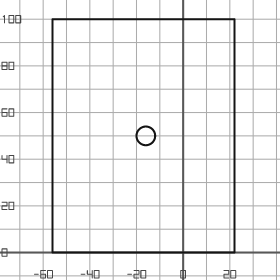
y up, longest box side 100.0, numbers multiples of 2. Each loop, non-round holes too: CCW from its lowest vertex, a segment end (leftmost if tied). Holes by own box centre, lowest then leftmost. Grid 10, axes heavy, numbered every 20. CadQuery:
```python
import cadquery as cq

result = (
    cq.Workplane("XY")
    .moveTo(-56.0, 0.0)
    .lineTo(22.0, 0.0)
    .lineTo(22.0, 100.0)
    .lineTo(-56.0, 100.0)
    .close()
    .moveTo(-16.0, 50.0)
    .circle(4.0)
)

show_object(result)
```